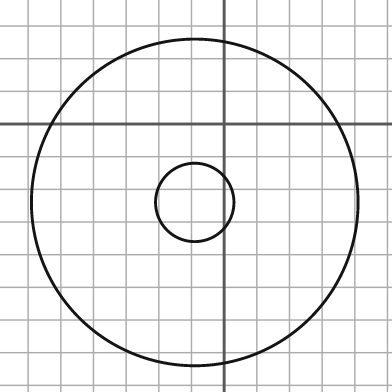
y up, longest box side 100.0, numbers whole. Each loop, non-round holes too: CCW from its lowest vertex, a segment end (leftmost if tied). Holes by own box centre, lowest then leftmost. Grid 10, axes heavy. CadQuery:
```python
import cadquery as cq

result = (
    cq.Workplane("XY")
    .moveTo(-9.0, -24.0)
    .circle(50.0)
    .moveTo(-9.0, -24.0)
    .circle(12.0)
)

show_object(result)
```